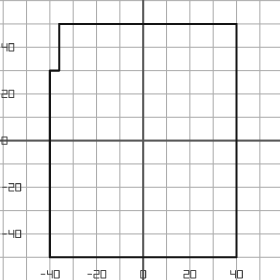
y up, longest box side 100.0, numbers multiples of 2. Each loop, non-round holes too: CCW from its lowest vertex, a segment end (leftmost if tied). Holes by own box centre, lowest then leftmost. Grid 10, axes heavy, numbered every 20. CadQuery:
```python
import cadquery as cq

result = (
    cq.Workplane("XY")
    .moveTo(-40.0, -50.0)
    .lineTo(40.0, -50.0)
    .lineTo(40.0, 50.0)
    .lineTo(-36.0, 50.0)
    .lineTo(-36.0, 30.0)
    .lineTo(-40.0, 30.0)
    .close()
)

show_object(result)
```